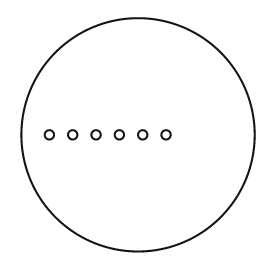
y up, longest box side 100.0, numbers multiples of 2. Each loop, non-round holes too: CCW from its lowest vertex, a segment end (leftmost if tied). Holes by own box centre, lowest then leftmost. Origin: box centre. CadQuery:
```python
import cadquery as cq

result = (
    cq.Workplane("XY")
    .moveTo(0.0, 0.0)
    .circle(50.0)
    .moveTo(-38.0, 0.0)
    .circle(2.0)
    .moveTo(-28.0, 0.0)
    .circle(2.0)
    .moveTo(-18.0, 0.0)
    .circle(2.0)
    .moveTo(-8.0, 0.0)
    .circle(2.0)
    .moveTo(2.0, 0.0)
    .circle(2.0)
    .moveTo(12.0, 0.0)
    .circle(2.0)
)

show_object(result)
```